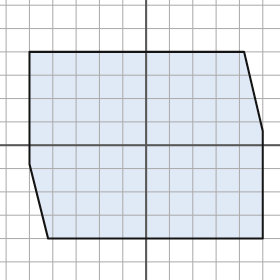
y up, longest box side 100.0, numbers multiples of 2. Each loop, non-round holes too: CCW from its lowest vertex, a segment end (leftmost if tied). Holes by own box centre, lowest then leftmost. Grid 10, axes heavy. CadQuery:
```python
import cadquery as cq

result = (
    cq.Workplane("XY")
    .moveTo(-42.0, -40.0)
    .lineTo(50.0, -40.0)
    .lineTo(50.0, 6.0)
    .lineTo(42.0, 40.0)
    .lineTo(-50.0, 40.0)
    .lineTo(-50.0, -8.0)
    .close()
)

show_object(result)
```